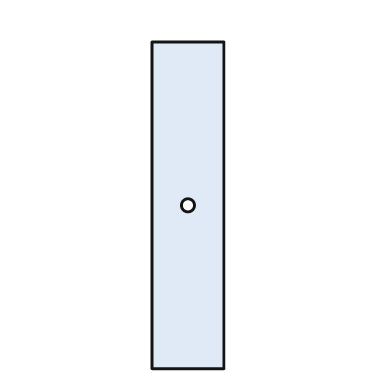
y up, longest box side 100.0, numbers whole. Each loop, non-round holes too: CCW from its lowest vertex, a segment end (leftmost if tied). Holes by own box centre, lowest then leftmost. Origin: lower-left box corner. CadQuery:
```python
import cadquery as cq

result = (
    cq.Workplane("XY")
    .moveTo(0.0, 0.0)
    .lineTo(22.0, 0.0)
    .lineTo(22.0, 100.0)
    .lineTo(0.0, 100.0)
    .close()
    .moveTo(11.0, 50.0)
    .circle(2.0)
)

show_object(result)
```